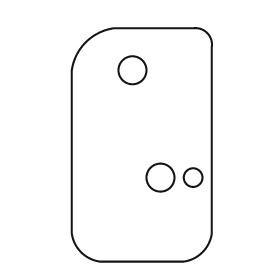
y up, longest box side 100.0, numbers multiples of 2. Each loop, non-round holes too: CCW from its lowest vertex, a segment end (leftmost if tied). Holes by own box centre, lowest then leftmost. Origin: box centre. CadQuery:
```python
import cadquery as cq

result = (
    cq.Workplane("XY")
    .moveTo(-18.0, -50.0)
    .lineTo(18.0, -50.0)
    .threePointArc((26.0, -46.0), (30.0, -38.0))
    .lineTo(30.0, 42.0)
    .threePointArc((28.0, 48.0), (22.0, 50.0))
    .lineTo(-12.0, 50.0)
    .threePointArc((-24.0, 44.0), (-30.0, 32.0))
    .lineTo(-30.0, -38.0)
    .threePointArc((-26.0, -46.0), (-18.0, -50.0))
    .close()
    .moveTo(8.0, -14.0)
    .circle(6.0)
    .moveTo(22.0, -14.0)
    .circle(4.0)
    .moveTo(-4.0, 32.0)
    .circle(6.0)
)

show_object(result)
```